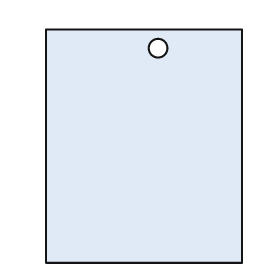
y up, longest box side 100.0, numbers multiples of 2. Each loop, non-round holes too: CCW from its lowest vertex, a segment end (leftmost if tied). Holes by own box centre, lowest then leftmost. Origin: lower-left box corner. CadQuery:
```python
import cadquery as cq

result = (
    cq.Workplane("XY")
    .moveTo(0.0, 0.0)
    .lineTo(84.0, 0.0)
    .lineTo(84.0, 100.0)
    .lineTo(0.0, 100.0)
    .close()
    .moveTo(48.0, 92.0)
    .circle(4.0)
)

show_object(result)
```